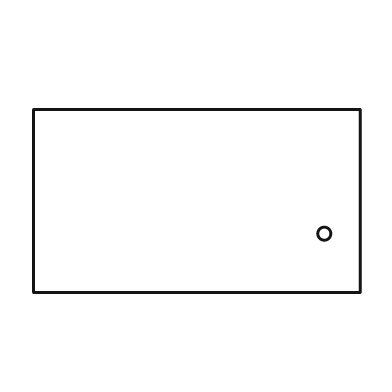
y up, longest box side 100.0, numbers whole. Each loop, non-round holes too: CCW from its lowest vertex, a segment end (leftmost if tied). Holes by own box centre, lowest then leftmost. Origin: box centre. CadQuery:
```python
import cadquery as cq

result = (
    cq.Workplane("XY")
    .moveTo(-50.0, -28.0)
    .lineTo(50.0, -28.0)
    .lineTo(50.0, 28.0)
    .lineTo(-50.0, 28.0)
    .close()
    .moveTo(39.0, -10.0)
    .circle(2.0)
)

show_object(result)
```